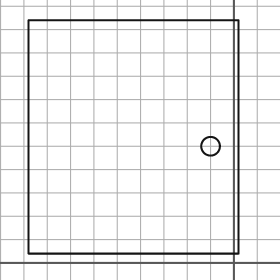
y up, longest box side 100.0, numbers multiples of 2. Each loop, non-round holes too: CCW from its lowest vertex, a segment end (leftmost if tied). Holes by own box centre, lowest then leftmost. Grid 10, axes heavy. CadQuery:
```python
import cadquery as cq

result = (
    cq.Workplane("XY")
    .moveTo(-88.0, 4.0)
    .lineTo(2.0, 4.0)
    .lineTo(2.0, 104.0)
    .lineTo(-88.0, 104.0)
    .close()
    .moveTo(-10.0, 50.0)
    .circle(4.0)
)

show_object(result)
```